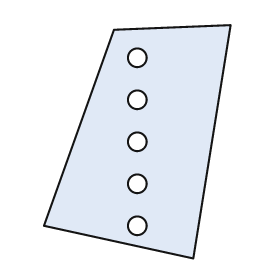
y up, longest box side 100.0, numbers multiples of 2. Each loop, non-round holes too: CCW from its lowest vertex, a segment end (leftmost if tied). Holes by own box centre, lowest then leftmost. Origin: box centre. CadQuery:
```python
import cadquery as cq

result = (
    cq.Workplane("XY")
    .moveTo(24.0, -50.0)
    .lineTo(40.0, 50.0)
    .lineTo(-10.0, 48.0)
    .lineTo(-40.0, -36.0)
    .close()
    .moveTo(0.0, -36.0)
    .circle(4.0)
    .moveTo(0.0, -18.0)
    .circle(4.0)
    .moveTo(0.0, 0.0)
    .circle(4.0)
    .moveTo(0.0, 18.0)
    .circle(4.0)
    .moveTo(0.0, 36.0)
    .circle(4.0)
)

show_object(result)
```